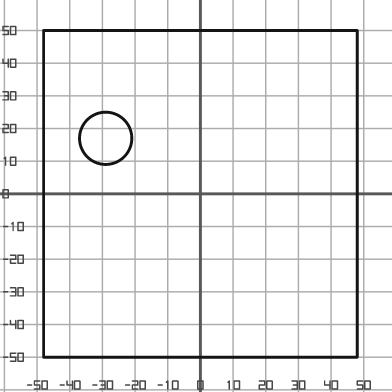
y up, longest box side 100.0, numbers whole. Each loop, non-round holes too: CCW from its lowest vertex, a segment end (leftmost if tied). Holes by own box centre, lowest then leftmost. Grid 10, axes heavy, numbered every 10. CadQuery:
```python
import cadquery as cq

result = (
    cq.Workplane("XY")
    .moveTo(-48.0, -50.0)
    .lineTo(48.0, -50.0)
    .lineTo(48.0, 50.0)
    .lineTo(-48.0, 50.0)
    .close()
    .moveTo(-29.0, 17.0)
    .circle(8.0)
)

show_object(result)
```